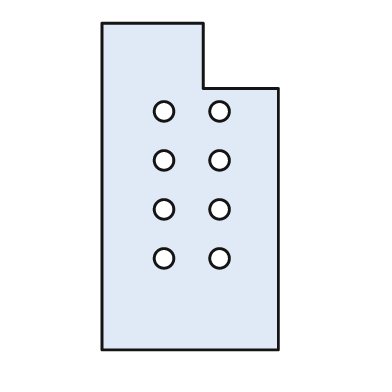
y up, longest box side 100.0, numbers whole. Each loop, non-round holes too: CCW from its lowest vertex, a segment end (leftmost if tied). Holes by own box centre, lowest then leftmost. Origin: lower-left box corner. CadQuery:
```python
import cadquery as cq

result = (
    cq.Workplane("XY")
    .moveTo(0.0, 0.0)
    .lineTo(54.0, 0.0)
    .lineTo(54.0, 80.0)
    .lineTo(31.0, 80.0)
    .lineTo(31.0, 100.0)
    .lineTo(0.0, 100.0)
    .close()
    .moveTo(19.0, 28.0)
    .circle(3.0)
    .moveTo(36.0, 28.0)
    .circle(3.0)
    .moveTo(19.0, 43.0)
    .circle(3.0)
    .moveTo(36.0, 43.0)
    .circle(3.0)
    .moveTo(19.0, 58.0)
    .circle(3.0)
    .moveTo(36.0, 58.0)
    .circle(3.0)
    .moveTo(19.0, 73.0)
    .circle(3.0)
    .moveTo(36.0, 73.0)
    .circle(3.0)
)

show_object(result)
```